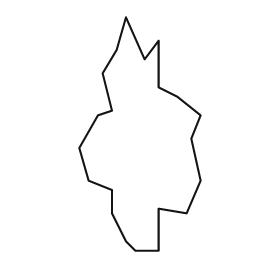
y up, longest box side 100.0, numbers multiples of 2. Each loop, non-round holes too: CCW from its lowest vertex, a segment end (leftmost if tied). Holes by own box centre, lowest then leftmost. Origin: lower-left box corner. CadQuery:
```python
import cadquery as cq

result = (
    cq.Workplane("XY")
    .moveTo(24.0, 0.0)
    .lineTo(34.0, 0.0)
    .lineTo(34.0, 18.0)
    .lineTo(46.0, 16.0)
    .lineTo(52.0, 30.0)
    .lineTo(48.0, 48.0)
    .lineTo(52.0, 58.0)
    .lineTo(42.0, 66.0)
    .lineTo(34.0, 70.0)
    .lineTo(34.0, 90.0)
    .lineTo(28.0, 82.0)
    .lineTo(20.0, 100.0)
    .lineTo(16.0, 86.0)
    .lineTo(10.0, 76.0)
    .lineTo(14.0, 60.0)
    .lineTo(8.0, 58.0)
    .lineTo(0.0, 44.0)
    .lineTo(4.0, 30.0)
    .lineTo(14.0, 26.0)
    .lineTo(14.0, 16.0)
    .lineTo(20.0, 4.0)
    .close()
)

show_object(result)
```